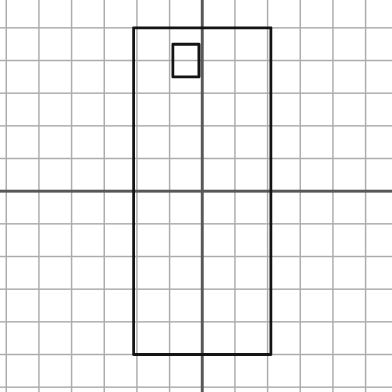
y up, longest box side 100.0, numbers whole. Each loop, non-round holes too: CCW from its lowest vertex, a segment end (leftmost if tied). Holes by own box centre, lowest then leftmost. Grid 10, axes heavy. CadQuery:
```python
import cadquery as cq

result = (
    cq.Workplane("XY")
    .moveTo(-21.0, -50.0)
    .lineTo(21.0, -50.0)
    .lineTo(21.0, 50.0)
    .lineTo(-21.0, 50.0)
    .close()
    .moveTo(-9.0, 35.0)
    .lineTo(-1.0, 35.0)
    .lineTo(-1.0, 45.0)
    .lineTo(-9.0, 45.0)
    .close()
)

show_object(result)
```